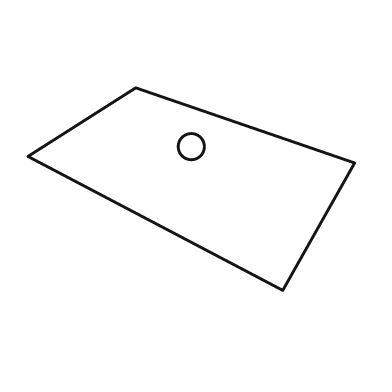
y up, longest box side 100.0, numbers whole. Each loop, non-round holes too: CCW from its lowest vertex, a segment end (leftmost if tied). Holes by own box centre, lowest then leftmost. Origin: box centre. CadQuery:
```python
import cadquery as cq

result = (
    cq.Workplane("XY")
    .moveTo(28.0, -31.0)
    .lineTo(50.0, 8.0)
    .lineTo(-17.0, 31.0)
    .lineTo(-50.0, 10.0)
    .close()
    .moveTo(0.0, 13.0)
    .circle(4.0)
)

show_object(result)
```